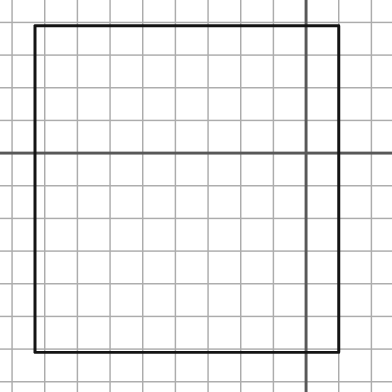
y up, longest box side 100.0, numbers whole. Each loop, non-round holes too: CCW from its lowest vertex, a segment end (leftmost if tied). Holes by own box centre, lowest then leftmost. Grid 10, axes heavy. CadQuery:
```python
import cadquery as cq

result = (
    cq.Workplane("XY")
    .moveTo(-83.0, -61.0)
    .lineTo(10.0, -61.0)
    .lineTo(10.0, 39.0)
    .lineTo(-83.0, 39.0)
    .close()
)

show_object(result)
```